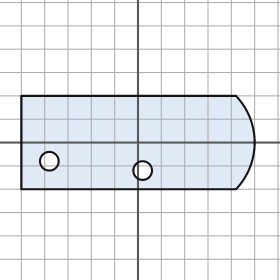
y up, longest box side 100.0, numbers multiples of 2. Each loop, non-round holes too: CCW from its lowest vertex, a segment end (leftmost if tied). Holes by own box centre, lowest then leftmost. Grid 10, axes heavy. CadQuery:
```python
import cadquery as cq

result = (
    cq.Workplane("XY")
    .moveTo(-50.0, -20.0)
    .lineTo(42.0, -20.0)
    .threePointArc((50.0, 0.0), (42.0, 20.0))
    .lineTo(-50.0, 20.0)
    .close()
    .moveTo(2.0, -12.0)
    .circle(4.0)
    .moveTo(-38.0, -8.0)
    .circle(4.0)
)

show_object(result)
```